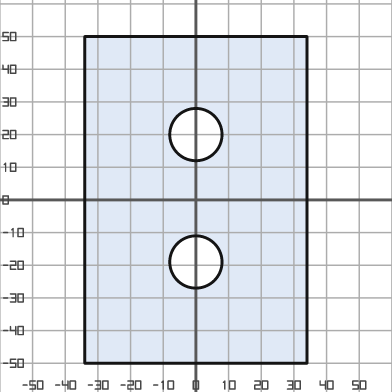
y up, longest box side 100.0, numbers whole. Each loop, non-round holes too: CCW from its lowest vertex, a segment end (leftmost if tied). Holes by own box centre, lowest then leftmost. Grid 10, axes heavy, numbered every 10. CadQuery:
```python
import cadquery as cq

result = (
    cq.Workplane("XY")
    .moveTo(-34.0, -50.0)
    .lineTo(34.0, -50.0)
    .lineTo(34.0, 50.0)
    .lineTo(-34.0, 50.0)
    .close()
    .moveTo(0.0, -19.0)
    .circle(8.0)
    .moveTo(0.0, 20.0)
    .circle(8.0)
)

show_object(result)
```